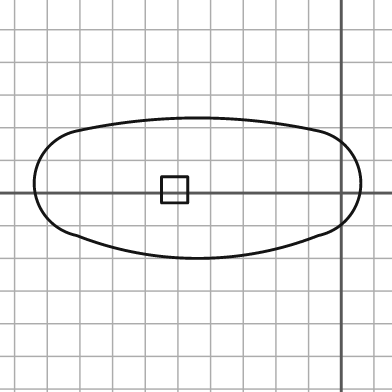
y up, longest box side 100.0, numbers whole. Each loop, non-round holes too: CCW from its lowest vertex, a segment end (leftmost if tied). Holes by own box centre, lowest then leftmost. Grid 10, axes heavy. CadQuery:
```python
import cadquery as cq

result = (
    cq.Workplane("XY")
    .moveTo(-81.0, -13.0)
    .threePointArc((-44.0, -20.0), (-7.0, -13.0))
    .threePointArc((6.0, 3.0), (-7.0, 19.0))
    .threePointArc((-44.0, 23.0), (-81.0, 19.0))
    .threePointArc((-94.0, 3.0), (-81.0, -13.0))
    .close()
    .moveTo(-55.0, -3.0)
    .lineTo(-47.0, -3.0)
    .lineTo(-47.0, 5.0)
    .lineTo(-55.0, 5.0)
    .close()
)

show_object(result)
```